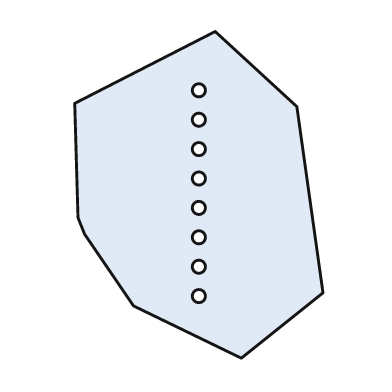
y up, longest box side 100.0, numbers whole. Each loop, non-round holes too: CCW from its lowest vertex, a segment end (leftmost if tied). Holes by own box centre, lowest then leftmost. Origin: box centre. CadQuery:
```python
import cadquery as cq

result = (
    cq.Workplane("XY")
    .moveTo(13.0, -50.0)
    .lineTo(38.0, -30.0)
    .lineTo(30.0, 27.0)
    .lineTo(5.0, 50.0)
    .lineTo(-38.0, 28.0)
    .lineTo(-37.0, -7.0)
    .lineTo(-35.0, -12.0)
    .lineTo(-20.0, -34.0)
    .close()
    .moveTo(0.0, -31.0)
    .circle(2.0)
    .moveTo(0.0, -22.0)
    .circle(2.0)
    .moveTo(0.0, -13.0)
    .circle(2.0)
    .moveTo(0.0, -4.0)
    .circle(2.0)
    .moveTo(0.0, 5.0)
    .circle(2.0)
    .moveTo(0.0, 14.0)
    .circle(2.0)
    .moveTo(0.0, 23.0)
    .circle(2.0)
    .moveTo(0.0, 32.0)
    .circle(2.0)
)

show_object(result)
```